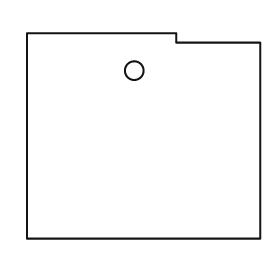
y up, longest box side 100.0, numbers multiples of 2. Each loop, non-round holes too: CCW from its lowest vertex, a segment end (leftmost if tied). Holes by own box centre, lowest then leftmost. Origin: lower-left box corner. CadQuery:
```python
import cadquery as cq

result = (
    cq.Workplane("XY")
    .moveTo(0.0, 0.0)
    .lineTo(100.0, 0.0)
    .lineTo(100.0, 84.0)
    .lineTo(64.0, 84.0)
    .lineTo(64.0, 88.0)
    .lineTo(0.0, 88.0)
    .close()
    .moveTo(46.0, 72.0)
    .circle(4.0)
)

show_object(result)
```